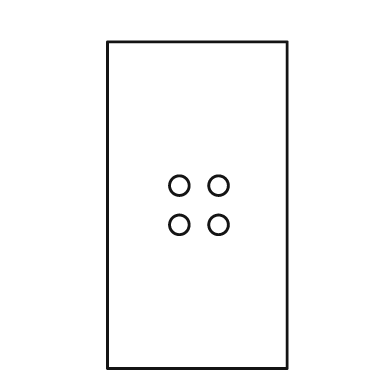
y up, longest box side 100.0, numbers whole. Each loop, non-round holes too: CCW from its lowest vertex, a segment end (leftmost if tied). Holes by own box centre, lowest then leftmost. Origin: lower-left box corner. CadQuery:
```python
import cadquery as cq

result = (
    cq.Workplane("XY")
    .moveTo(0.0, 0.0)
    .lineTo(55.0, 0.0)
    .lineTo(55.0, 100.0)
    .lineTo(0.0, 100.0)
    .close()
    .moveTo(22.0, 44.0)
    .circle(3.0)
    .moveTo(34.0, 44.0)
    .circle(3.0)
    .moveTo(22.0, 56.0)
    .circle(3.0)
    .moveTo(34.0, 56.0)
    .circle(3.0)
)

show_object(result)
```